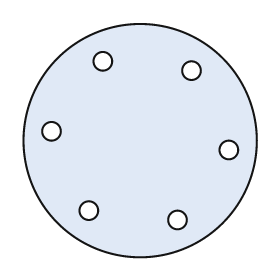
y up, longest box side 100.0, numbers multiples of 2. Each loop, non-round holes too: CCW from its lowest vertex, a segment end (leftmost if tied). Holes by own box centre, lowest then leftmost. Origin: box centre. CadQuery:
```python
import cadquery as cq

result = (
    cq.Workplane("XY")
    .moveTo(0.0, 0.0)
    .circle(50.0)
    .moveTo(16.0, -34.0)
    .circle(4.0)
    .moveTo(-22.0, -30.0)
    .circle(4.0)
    .moveTo(38.0, -4.0)
    .circle(4.0)
    .moveTo(-38.0, 4.0)
    .circle(4.0)
    .moveTo(22.0, 30.0)
    .circle(4.0)
    .moveTo(-16.0, 34.0)
    .circle(4.0)
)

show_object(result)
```